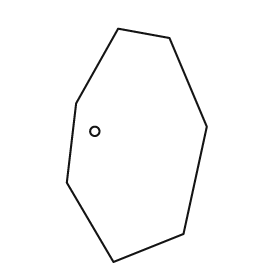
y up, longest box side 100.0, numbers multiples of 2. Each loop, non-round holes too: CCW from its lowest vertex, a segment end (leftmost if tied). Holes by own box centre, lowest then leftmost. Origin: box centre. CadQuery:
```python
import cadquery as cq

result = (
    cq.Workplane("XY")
    .moveTo(-10.0, -50.0)
    .lineTo(20.0, -38.0)
    .lineTo(30.0, 8.0)
    .lineTo(14.0, 46.0)
    .lineTo(-8.0, 50.0)
    .lineTo(-26.0, 18.0)
    .lineTo(-30.0, -16.0)
    .close()
    .moveTo(-18.0, 6.0)
    .circle(2.0)
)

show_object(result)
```